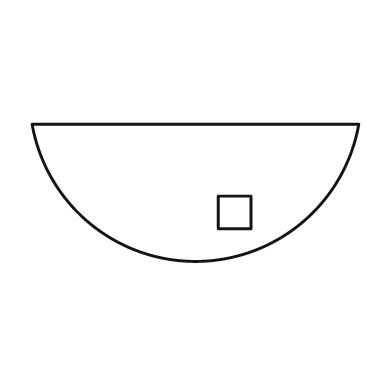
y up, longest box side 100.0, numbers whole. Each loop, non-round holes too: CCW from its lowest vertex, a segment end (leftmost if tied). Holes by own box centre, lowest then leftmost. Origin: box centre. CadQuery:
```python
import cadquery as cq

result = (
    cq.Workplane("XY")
    .moveTo(-50.0, 21.0)
    .threePointArc((0.0, -21.0), (50.0, 21.0))
    .close()
    .moveTo(7.0, -11.0)
    .lineTo(17.0, -11.0)
    .lineTo(17.0, -1.0)
    .lineTo(7.0, -1.0)
    .close()
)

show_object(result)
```